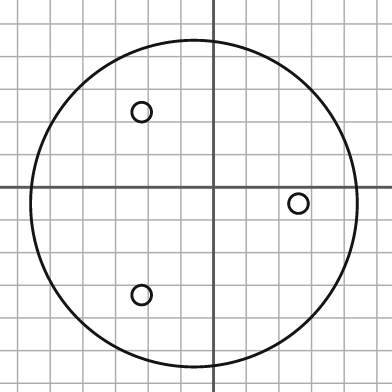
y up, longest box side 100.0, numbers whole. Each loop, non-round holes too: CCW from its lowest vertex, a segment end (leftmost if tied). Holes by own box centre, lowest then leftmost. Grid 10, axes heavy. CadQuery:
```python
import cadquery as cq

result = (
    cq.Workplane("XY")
    .moveTo(-6.0, -5.0)
    .circle(50.0)
    .moveTo(-22.0, -33.0)
    .circle(3.0)
    .moveTo(26.0, -5.0)
    .circle(3.0)
    .moveTo(-22.0, 23.0)
    .circle(3.0)
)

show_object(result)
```